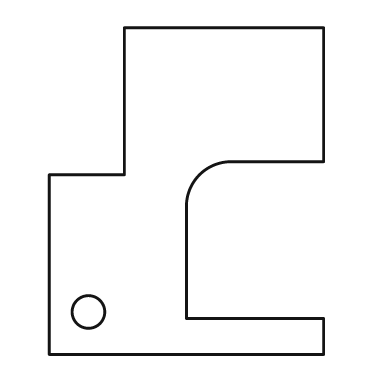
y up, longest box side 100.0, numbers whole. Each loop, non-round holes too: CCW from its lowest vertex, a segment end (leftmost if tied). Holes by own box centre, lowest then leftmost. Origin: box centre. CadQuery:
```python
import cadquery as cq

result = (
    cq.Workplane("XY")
    .moveTo(-42.0, -50.0)
    .lineTo(42.0, -50.0)
    .lineTo(42.0, -39.0)
    .lineTo(0.0, -39.0)
    .lineTo(0.0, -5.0)
    .threePointArc((4.0, 5.0), (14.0, 9.0))
    .lineTo(42.0, 9.0)
    .lineTo(42.0, 50.0)
    .lineTo(-19.0, 50.0)
    .lineTo(-19.0, 5.0)
    .lineTo(-42.0, 5.0)
    .close()
    .moveTo(-30.0, -37.0)
    .circle(5.0)
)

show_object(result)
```